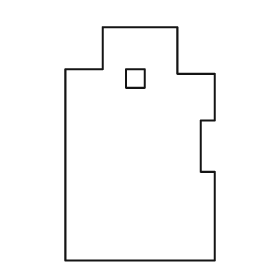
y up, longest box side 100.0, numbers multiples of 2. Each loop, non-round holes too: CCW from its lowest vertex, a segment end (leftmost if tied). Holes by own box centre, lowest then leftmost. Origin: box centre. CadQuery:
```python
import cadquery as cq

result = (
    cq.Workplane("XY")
    .moveTo(-32.0, -50.0)
    .lineTo(32.0, -50.0)
    .lineTo(32.0, -12.0)
    .lineTo(26.0, -12.0)
    .lineTo(26.0, 10.0)
    .lineTo(32.0, 10.0)
    .lineTo(32.0, 30.0)
    .lineTo(16.0, 30.0)
    .lineTo(16.0, 50.0)
    .lineTo(-16.0, 50.0)
    .lineTo(-16.0, 32.0)
    .lineTo(-32.0, 32.0)
    .close()
    .moveTo(-6.0, 24.0)
    .lineTo(2.0, 24.0)
    .lineTo(2.0, 32.0)
    .lineTo(-6.0, 32.0)
    .close()
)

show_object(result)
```